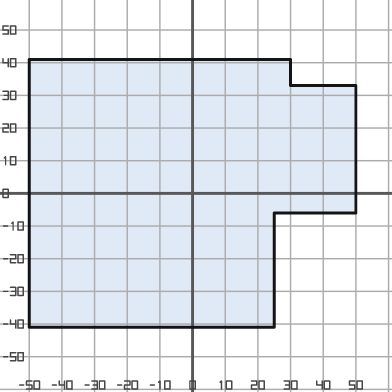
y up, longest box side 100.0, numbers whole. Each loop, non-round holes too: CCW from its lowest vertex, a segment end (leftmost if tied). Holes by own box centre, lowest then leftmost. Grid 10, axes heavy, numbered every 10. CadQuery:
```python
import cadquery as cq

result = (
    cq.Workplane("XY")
    .moveTo(-50.0, -41.0)
    .lineTo(25.0, -41.0)
    .lineTo(25.0, -6.0)
    .lineTo(50.0, -6.0)
    .lineTo(50.0, 33.0)
    .lineTo(30.0, 33.0)
    .lineTo(30.0, 41.0)
    .lineTo(-50.0, 41.0)
    .close()
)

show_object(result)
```